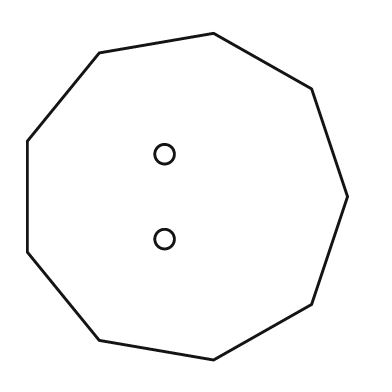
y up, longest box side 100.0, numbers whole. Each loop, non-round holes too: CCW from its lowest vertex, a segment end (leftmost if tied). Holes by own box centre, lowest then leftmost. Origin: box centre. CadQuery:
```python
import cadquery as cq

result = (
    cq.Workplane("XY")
    .moveTo(8.0, -50.0)
    .lineTo(38.0, -33.0)
    .lineTo(49.0, 0.0)
    .lineTo(38.0, 33.0)
    .lineTo(8.0, 50.0)
    .lineTo(-27.0, 44.0)
    .lineTo(-49.0, 17.0)
    .lineTo(-49.0, -17.0)
    .lineTo(-27.0, -44.0)
    .close()
    .moveTo(-7.0, -13.0)
    .circle(3.0)
    .moveTo(-7.0, 13.0)
    .circle(3.0)
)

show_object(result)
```